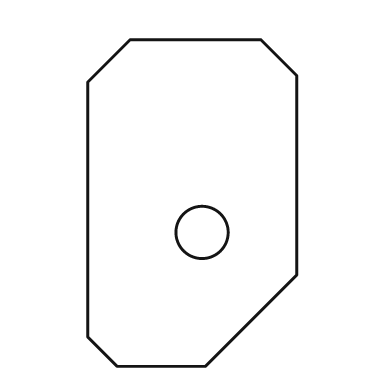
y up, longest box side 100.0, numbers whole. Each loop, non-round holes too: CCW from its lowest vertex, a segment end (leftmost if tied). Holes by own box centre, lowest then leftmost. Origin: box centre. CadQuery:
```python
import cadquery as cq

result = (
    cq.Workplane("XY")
    .moveTo(-23.0, -50.0)
    .lineTo(4.0, -50.0)
    .lineTo(32.0, -22.0)
    .lineTo(32.0, 39.0)
    .lineTo(21.0, 50.0)
    .lineTo(-19.0, 50.0)
    .lineTo(-32.0, 37.0)
    .lineTo(-32.0, -41.0)
    .close()
    .moveTo(3.0, -9.0)
    .circle(8.0)
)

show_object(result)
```